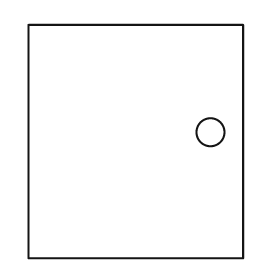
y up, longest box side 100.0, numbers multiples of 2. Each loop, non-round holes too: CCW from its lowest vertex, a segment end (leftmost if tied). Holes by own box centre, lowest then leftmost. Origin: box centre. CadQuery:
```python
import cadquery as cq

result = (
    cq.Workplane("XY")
    .moveTo(-46.0, -50.0)
    .lineTo(46.0, -50.0)
    .lineTo(46.0, 50.0)
    .lineTo(-46.0, 50.0)
    .close()
    .moveTo(32.0, 4.0)
    .circle(6.0)
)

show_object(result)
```